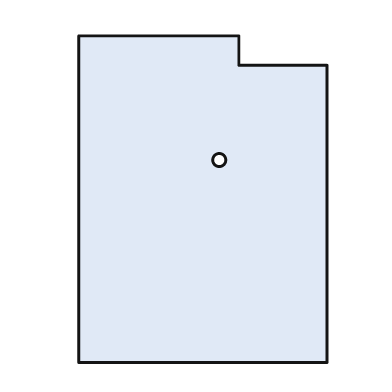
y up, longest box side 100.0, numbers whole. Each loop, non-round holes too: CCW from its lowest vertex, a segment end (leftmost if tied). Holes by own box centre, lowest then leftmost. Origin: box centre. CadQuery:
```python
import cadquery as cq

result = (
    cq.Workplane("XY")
    .moveTo(-38.0, -50.0)
    .lineTo(38.0, -50.0)
    .lineTo(38.0, 41.0)
    .lineTo(11.0, 41.0)
    .lineTo(11.0, 50.0)
    .lineTo(-38.0, 50.0)
    .close()
    .moveTo(5.0, 12.0)
    .circle(2.0)
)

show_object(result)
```